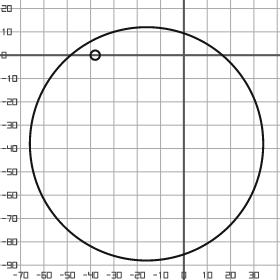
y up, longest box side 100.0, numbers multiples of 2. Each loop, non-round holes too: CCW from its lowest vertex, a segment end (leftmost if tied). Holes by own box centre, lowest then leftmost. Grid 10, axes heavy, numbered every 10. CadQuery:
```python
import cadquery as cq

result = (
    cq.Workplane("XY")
    .moveTo(-16.0, -38.0)
    .circle(50.0)
    .moveTo(-38.0, 0.0)
    .circle(2.0)
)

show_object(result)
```